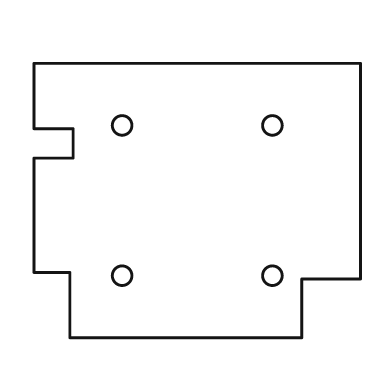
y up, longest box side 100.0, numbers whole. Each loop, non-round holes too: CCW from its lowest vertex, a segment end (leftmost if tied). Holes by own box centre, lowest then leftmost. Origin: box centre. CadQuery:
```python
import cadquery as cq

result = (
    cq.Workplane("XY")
    .moveTo(-39.0, -42.0)
    .lineTo(32.0, -42.0)
    .lineTo(32.0, -24.0)
    .lineTo(50.0, -24.0)
    .lineTo(50.0, 42.0)
    .lineTo(-50.0, 42.0)
    .lineTo(-50.0, 22.0)
    .lineTo(-38.0, 22.0)
    .lineTo(-38.0, 13.0)
    .lineTo(-50.0, 13.0)
    .lineTo(-50.0, -22.0)
    .lineTo(-39.0, -22.0)
    .close()
    .moveTo(-23.0, -23.0)
    .circle(3.0)
    .moveTo(23.0, -23.0)
    .circle(3.0)
    .moveTo(-23.0, 23.0)
    .circle(3.0)
    .moveTo(23.0, 23.0)
    .circle(3.0)
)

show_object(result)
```